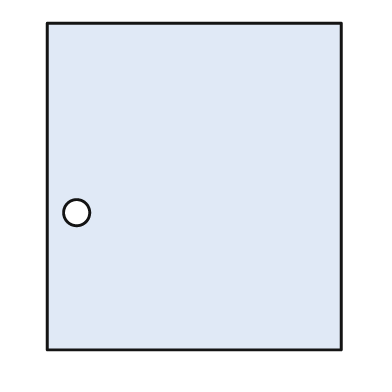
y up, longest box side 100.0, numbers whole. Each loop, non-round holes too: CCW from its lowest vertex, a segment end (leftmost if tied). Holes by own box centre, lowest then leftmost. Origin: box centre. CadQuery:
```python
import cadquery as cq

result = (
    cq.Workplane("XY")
    .moveTo(-45.0, -50.0)
    .lineTo(45.0, -50.0)
    .lineTo(45.0, 50.0)
    .lineTo(-45.0, 50.0)
    .close()
    .moveTo(-36.0, -8.0)
    .circle(4.0)
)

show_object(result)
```